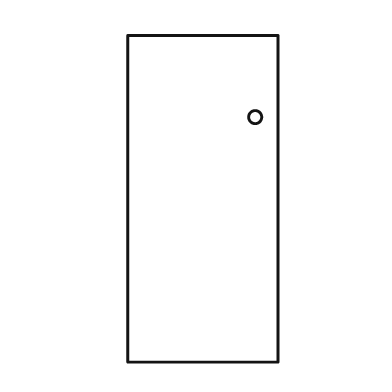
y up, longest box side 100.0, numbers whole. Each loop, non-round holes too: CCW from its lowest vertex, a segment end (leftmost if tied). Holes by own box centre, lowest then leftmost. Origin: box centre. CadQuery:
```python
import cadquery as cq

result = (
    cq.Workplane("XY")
    .moveTo(-23.0, -50.0)
    .lineTo(23.0, -50.0)
    .lineTo(23.0, 50.0)
    .lineTo(-23.0, 50.0)
    .close()
    .moveTo(16.0, 25.0)
    .circle(2.0)
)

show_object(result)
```